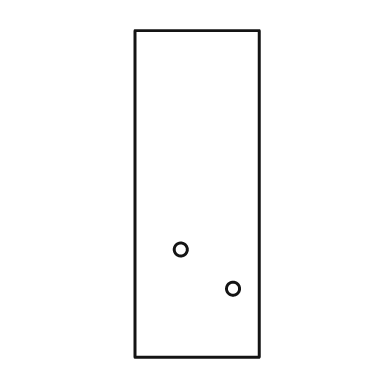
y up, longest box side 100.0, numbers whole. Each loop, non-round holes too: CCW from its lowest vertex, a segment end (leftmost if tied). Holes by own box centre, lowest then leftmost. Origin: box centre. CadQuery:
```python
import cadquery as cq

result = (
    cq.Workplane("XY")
    .moveTo(-19.0, -50.0)
    .lineTo(19.0, -50.0)
    .lineTo(19.0, 50.0)
    .lineTo(-19.0, 50.0)
    .close()
    .moveTo(11.0, -29.0)
    .circle(2.0)
    .moveTo(-5.0, -17.0)
    .circle(2.0)
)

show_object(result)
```